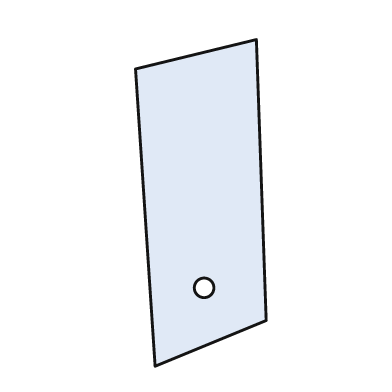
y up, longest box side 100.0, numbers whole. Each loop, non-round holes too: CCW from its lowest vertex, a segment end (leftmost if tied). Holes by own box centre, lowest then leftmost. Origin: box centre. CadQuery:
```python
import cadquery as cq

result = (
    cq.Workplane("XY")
    .moveTo(-14.0, -50.0)
    .lineTo(20.0, -36.0)
    .lineTo(17.0, 50.0)
    .lineTo(-20.0, 41.0)
    .close()
    .moveTo(1.0, -26.0)
    .circle(3.0)
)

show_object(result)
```